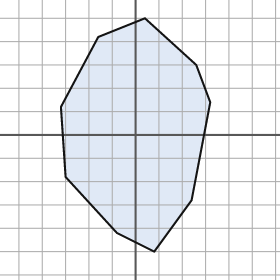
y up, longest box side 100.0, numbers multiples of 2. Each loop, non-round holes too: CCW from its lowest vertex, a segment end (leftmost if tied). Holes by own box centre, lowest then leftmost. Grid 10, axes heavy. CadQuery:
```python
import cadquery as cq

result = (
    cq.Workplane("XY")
    .moveTo(8.0, -50.0)
    .lineTo(24.0, -28.0)
    .lineTo(32.0, 14.0)
    .lineTo(26.0, 30.0)
    .lineTo(4.0, 50.0)
    .lineTo(-16.0, 42.0)
    .lineTo(-32.0, 12.0)
    .lineTo(-30.0, -18.0)
    .lineTo(-8.0, -42.0)
    .close()
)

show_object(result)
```